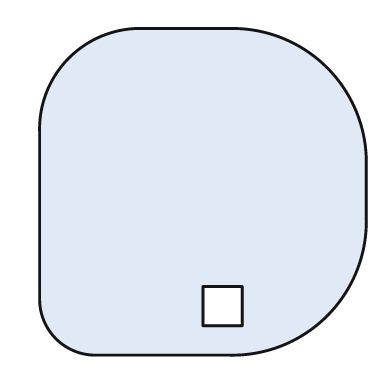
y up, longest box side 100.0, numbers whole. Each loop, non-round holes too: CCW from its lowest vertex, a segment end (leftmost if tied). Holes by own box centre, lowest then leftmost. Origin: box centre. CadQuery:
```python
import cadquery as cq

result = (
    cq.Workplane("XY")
    .moveTo(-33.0, -50.0)
    .lineTo(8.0, -50.0)
    .threePointArc((38.0, -38.0), (50.0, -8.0))
    .lineTo(50.0, 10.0)
    .threePointArc((38.0, 38.0), (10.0, 50.0))
    .lineTo(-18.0, 50.0)
    .threePointArc((-41.0, 41.0), (-50.0, 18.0))
    .lineTo(-50.0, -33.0)
    .threePointArc((-45.0, -45.0), (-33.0, -50.0))
    .close()
    .moveTo(0.0, -41.0)
    .lineTo(12.0, -41.0)
    .lineTo(12.0, -29.0)
    .lineTo(0.0, -29.0)
    .close()
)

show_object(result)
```